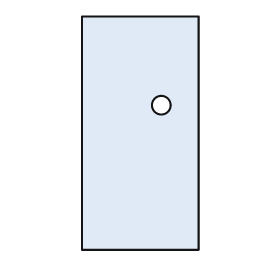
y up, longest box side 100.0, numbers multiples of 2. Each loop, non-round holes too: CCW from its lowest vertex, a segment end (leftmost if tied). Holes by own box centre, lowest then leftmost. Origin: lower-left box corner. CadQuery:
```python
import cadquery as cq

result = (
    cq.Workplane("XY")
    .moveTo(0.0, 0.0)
    .lineTo(50.0, 0.0)
    .lineTo(50.0, 100.0)
    .lineTo(0.0, 100.0)
    .close()
    .moveTo(34.0, 62.0)
    .circle(4.0)
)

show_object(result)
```